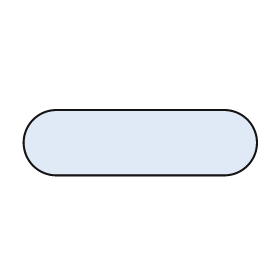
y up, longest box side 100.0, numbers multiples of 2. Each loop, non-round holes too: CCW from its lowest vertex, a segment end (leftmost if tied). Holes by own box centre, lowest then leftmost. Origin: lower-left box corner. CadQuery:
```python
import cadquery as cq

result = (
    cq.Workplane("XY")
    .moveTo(14.0, 0.0)
    .lineTo(86.0, 0.0)
    .threePointArc((100.0, 14.0), (86.0, 28.0))
    .lineTo(14.0, 28.0)
    .threePointArc((0.0, 14.0), (14.0, 0.0))
    .close()
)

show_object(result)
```